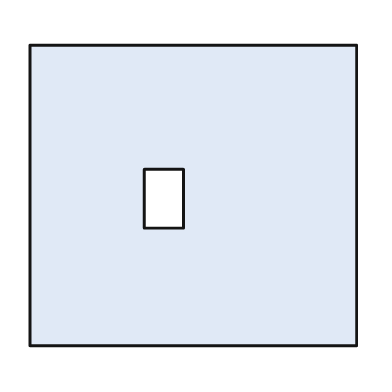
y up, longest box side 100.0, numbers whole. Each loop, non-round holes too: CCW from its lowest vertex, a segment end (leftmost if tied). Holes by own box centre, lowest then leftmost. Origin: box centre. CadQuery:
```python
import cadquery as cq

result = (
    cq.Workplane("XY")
    .moveTo(-50.0, -46.0)
    .lineTo(50.0, -46.0)
    .lineTo(50.0, 46.0)
    .lineTo(-50.0, 46.0)
    .close()
    .moveTo(-15.0, -10.0)
    .lineTo(-3.0, -10.0)
    .lineTo(-3.0, 8.0)
    .lineTo(-15.0, 8.0)
    .close()
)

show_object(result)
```